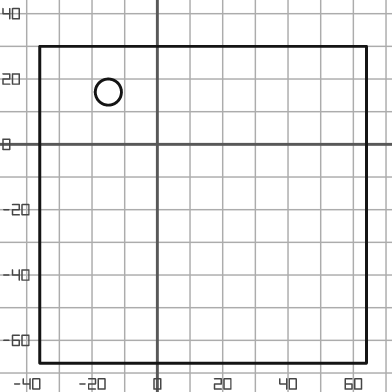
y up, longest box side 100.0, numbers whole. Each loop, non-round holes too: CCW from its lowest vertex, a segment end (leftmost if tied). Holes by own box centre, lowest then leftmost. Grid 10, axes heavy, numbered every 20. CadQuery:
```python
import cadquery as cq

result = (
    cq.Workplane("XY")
    .moveTo(-36.0, -67.0)
    .lineTo(64.0, -67.0)
    .lineTo(64.0, 30.0)
    .lineTo(-36.0, 30.0)
    .close()
    .moveTo(-15.0, 16.0)
    .circle(4.0)
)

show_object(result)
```